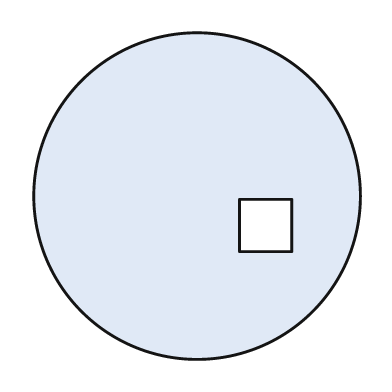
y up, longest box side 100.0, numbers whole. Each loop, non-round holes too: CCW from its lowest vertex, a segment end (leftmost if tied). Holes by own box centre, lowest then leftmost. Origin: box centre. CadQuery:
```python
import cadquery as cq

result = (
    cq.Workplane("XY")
    .moveTo(0.0, 0.0)
    .circle(50.0)
    .moveTo(13.0, -17.0)
    .lineTo(29.0, -17.0)
    .lineTo(29.0, -1.0)
    .lineTo(13.0, -1.0)
    .close()
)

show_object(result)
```